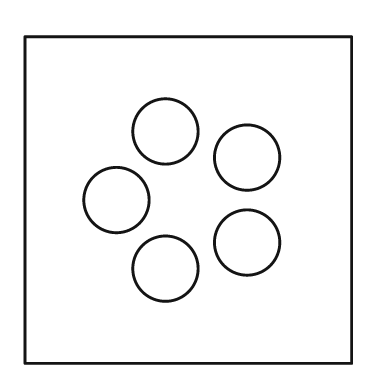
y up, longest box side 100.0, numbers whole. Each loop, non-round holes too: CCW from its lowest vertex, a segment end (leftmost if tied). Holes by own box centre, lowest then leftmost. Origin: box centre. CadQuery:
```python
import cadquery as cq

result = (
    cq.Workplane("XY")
    .moveTo(-50.0, -50.0)
    .lineTo(50.0, -50.0)
    .lineTo(50.0, 50.0)
    .lineTo(-50.0, 50.0)
    .close()
    .moveTo(-7.0, -21.0)
    .circle(10.0)
    .moveTo(18.0, -13.0)
    .circle(10.0)
    .moveTo(-22.0, 0.0)
    .circle(10.0)
    .moveTo(18.0, 13.0)
    .circle(10.0)
    .moveTo(-7.0, 21.0)
    .circle(10.0)
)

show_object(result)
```